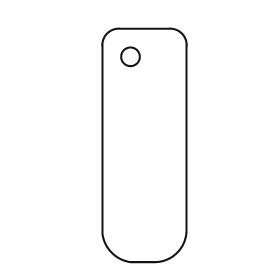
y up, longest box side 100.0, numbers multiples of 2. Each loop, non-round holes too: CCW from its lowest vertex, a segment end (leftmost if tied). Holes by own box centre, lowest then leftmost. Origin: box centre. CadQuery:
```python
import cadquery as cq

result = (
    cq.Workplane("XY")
    .moveTo(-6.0, -50.0)
    .lineTo(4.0, -50.0)
    .threePointArc((14.0, -46.0), (18.0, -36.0))
    .lineTo(18.0, 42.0)
    .threePointArc((16.0, 48.0), (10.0, 50.0))
    .lineTo(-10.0, 50.0)
    .threePointArc((-16.0, 48.0), (-18.0, 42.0))
    .lineTo(-18.0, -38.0)
    .threePointArc((-14.0, -46.0), (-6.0, -50.0))
    .close()
    .moveTo(-6.0, 38.0)
    .circle(4.0)
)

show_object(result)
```